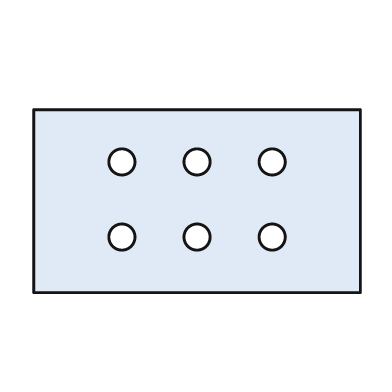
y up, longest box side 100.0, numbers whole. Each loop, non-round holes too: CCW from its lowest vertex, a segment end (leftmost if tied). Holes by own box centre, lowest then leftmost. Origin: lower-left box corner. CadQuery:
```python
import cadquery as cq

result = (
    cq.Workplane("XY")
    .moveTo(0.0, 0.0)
    .lineTo(100.0, 0.0)
    .lineTo(100.0, 56.0)
    .lineTo(0.0, 56.0)
    .close()
    .moveTo(27.0, 17.0)
    .circle(4.0)
    .moveTo(50.0, 17.0)
    .circle(4.0)
    .moveTo(73.0, 17.0)
    .circle(4.0)
    .moveTo(27.0, 40.0)
    .circle(4.0)
    .moveTo(50.0, 40.0)
    .circle(4.0)
    .moveTo(73.0, 40.0)
    .circle(4.0)
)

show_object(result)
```